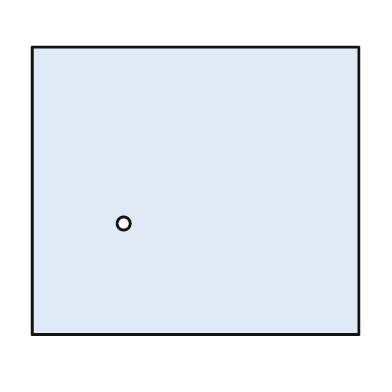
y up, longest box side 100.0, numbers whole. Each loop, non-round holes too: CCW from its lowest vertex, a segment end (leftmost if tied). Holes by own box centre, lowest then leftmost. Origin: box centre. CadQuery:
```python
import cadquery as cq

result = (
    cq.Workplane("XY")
    .moveTo(-50.0, -44.0)
    .lineTo(50.0, -44.0)
    .lineTo(50.0, 44.0)
    .lineTo(-50.0, 44.0)
    .close()
    .moveTo(-22.0, -10.0)
    .circle(2.0)
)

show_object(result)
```